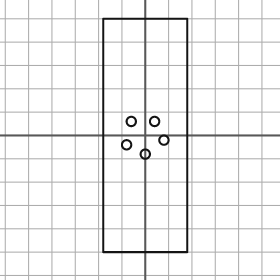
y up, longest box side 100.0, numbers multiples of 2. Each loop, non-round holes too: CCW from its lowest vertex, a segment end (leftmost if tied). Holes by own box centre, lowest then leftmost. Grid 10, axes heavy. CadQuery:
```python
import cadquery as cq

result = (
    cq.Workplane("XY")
    .moveTo(-18.0, -50.0)
    .lineTo(18.0, -50.0)
    .lineTo(18.0, 50.0)
    .lineTo(-18.0, 50.0)
    .close()
    .moveTo(0.0, -8.0)
    .circle(2.0)
    .moveTo(-8.0, -4.0)
    .circle(2.0)
    .moveTo(8.0, -2.0)
    .circle(2.0)
    .moveTo(-6.0, 6.0)
    .circle(2.0)
    .moveTo(4.0, 6.0)
    .circle(2.0)
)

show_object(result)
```